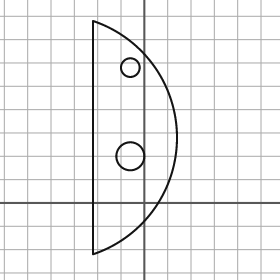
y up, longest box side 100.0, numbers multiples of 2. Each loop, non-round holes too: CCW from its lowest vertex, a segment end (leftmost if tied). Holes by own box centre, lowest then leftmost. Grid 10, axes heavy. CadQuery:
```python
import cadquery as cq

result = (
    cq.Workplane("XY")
    .moveTo(-22.0, -22.0)
    .threePointArc((14.0, 28.0), (-22.0, 78.0))
    .close()
    .moveTo(-6.0, 20.0)
    .circle(6.0)
    .moveTo(-6.0, 58.0)
    .circle(4.0)
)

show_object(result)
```